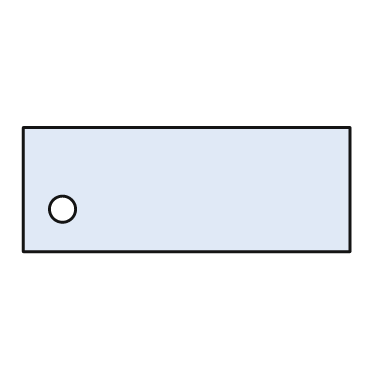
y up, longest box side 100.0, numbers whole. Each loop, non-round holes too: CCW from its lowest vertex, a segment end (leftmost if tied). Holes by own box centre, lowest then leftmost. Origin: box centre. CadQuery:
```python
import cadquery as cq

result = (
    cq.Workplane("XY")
    .moveTo(-50.0, -19.0)
    .lineTo(50.0, -19.0)
    .lineTo(50.0, 19.0)
    .lineTo(-50.0, 19.0)
    .close()
    .moveTo(-38.0, -6.0)
    .circle(4.0)
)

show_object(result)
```